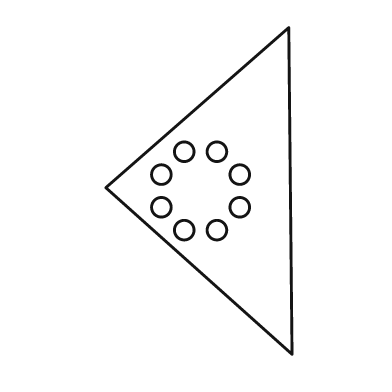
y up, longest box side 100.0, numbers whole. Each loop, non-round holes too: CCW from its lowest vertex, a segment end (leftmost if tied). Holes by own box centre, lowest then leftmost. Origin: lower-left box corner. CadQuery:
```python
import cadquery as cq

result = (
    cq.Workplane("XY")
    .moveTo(57.0, 0.0)
    .lineTo(56.0, 100.0)
    .lineTo(0.0, 51.0)
    .close()
    .moveTo(24.0, 38.0)
    .circle(3.0)
    .moveTo(34.0, 38.0)
    .circle(3.0)
    .moveTo(17.0, 45.0)
    .circle(3.0)
    .moveTo(41.0, 45.0)
    .circle(3.0)
    .moveTo(17.0, 55.0)
    .circle(3.0)
    .moveTo(41.0, 55.0)
    .circle(3.0)
    .moveTo(24.0, 62.0)
    .circle(3.0)
    .moveTo(34.0, 62.0)
    .circle(3.0)
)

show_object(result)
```